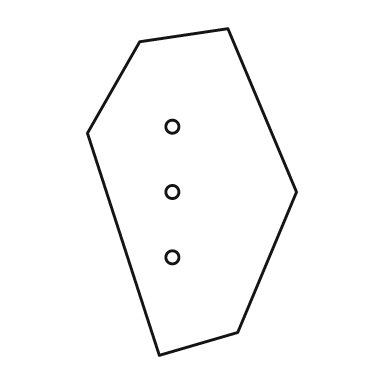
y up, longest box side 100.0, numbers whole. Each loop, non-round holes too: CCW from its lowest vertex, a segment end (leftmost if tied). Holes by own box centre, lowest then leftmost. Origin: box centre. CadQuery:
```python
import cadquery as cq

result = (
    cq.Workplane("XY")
    .moveTo(-10.0, -50.0)
    .lineTo(14.0, -43.0)
    .lineTo(32.0, 0.0)
    .lineTo(11.0, 50.0)
    .lineTo(-16.0, 46.0)
    .lineTo(-32.0, 18.0)
    .close()
    .moveTo(-6.0, -20.0)
    .circle(2.0)
    .moveTo(-6.0, 0.0)
    .circle(2.0)
    .moveTo(-6.0, 20.0)
    .circle(2.0)
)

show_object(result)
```